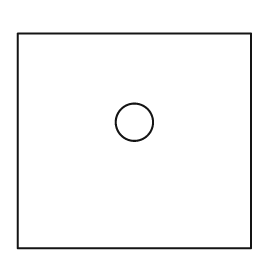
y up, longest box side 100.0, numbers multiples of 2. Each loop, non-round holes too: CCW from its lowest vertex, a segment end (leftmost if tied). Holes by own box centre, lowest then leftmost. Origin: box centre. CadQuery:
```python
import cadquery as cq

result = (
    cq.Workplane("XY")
    .moveTo(-50.0, -46.0)
    .lineTo(50.0, -46.0)
    .lineTo(50.0, 46.0)
    .lineTo(-50.0, 46.0)
    .close()
    .moveTo(0.0, 8.0)
    .circle(8.0)
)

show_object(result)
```